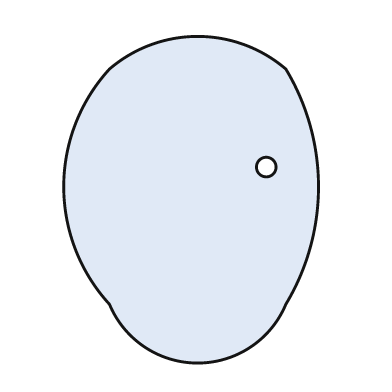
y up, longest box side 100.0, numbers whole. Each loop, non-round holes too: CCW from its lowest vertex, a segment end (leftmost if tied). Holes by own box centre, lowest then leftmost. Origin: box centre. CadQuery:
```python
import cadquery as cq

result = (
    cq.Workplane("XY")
    .moveTo(-25.0, -32.0)
    .threePointArc((2.0, -50.0), (29.0, -32.0))
    .threePointArc((39.0, 4.0), (29.0, 40.0))
    .threePointArc((2.0, 50.0), (-25.0, 40.0))
    .threePointArc((-39.0, 4.0), (-25.0, -32.0))
    .close()
    .moveTo(23.0, 10.0)
    .circle(3.0)
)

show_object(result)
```